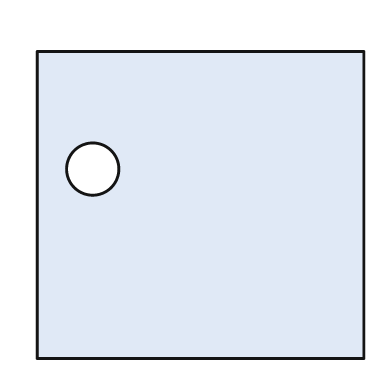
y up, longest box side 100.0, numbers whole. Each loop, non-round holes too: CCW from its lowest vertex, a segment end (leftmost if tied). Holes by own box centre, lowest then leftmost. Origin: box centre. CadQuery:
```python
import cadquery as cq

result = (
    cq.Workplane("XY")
    .moveTo(-50.0, -47.0)
    .lineTo(50.0, -47.0)
    .lineTo(50.0, 47.0)
    .lineTo(-50.0, 47.0)
    .close()
    .moveTo(-33.0, 11.0)
    .circle(8.0)
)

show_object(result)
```